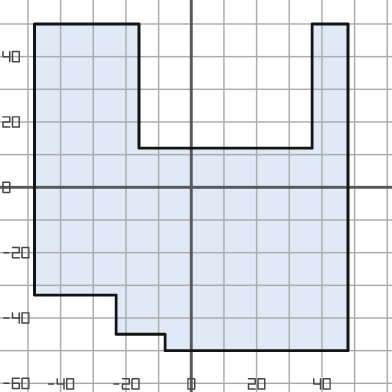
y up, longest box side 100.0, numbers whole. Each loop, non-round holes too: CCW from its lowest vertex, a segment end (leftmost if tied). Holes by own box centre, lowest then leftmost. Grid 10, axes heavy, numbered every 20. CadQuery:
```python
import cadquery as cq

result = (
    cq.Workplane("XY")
    .moveTo(-8.0, -50.0)
    .lineTo(48.0, -50.0)
    .lineTo(48.0, 50.0)
    .lineTo(37.0, 50.0)
    .lineTo(37.0, 12.0)
    .lineTo(-16.0, 12.0)
    .lineTo(-16.0, 50.0)
    .lineTo(-48.0, 50.0)
    .lineTo(-48.0, -33.0)
    .lineTo(-23.0, -33.0)
    .lineTo(-23.0, -45.0)
    .lineTo(-8.0, -45.0)
    .close()
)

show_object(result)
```